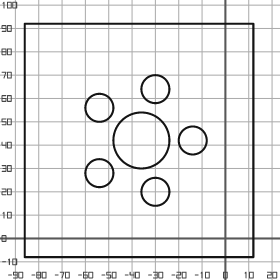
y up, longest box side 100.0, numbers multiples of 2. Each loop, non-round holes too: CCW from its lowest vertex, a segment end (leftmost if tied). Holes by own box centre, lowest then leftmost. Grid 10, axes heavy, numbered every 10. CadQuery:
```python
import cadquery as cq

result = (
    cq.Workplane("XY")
    .moveTo(-86.0, -8.0)
    .lineTo(12.0, -8.0)
    .lineTo(12.0, 92.0)
    .lineTo(-86.0, 92.0)
    .close()
    .moveTo(-30.0, 20.0)
    .circle(6.0)
    .moveTo(-54.0, 28.0)
    .circle(6.0)
    .moveTo(-36.0, 42.0)
    .circle(12.0)
    .moveTo(-14.0, 42.0)
    .circle(6.0)
    .moveTo(-54.0, 56.0)
    .circle(6.0)
    .moveTo(-30.0, 64.0)
    .circle(6.0)
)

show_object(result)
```